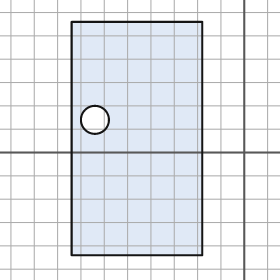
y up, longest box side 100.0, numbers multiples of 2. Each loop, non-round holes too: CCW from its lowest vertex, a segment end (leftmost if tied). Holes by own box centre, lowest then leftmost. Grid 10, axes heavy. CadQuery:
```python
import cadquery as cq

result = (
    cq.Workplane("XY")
    .moveTo(-74.0, -44.0)
    .lineTo(-18.0, -44.0)
    .lineTo(-18.0, 56.0)
    .lineTo(-74.0, 56.0)
    .close()
    .moveTo(-64.0, 14.0)
    .circle(6.0)
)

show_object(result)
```